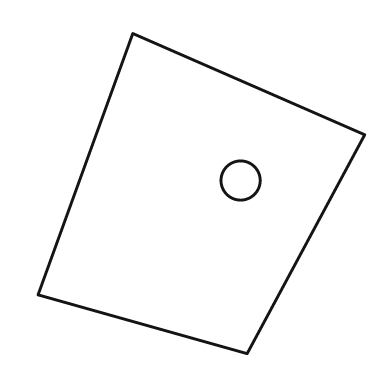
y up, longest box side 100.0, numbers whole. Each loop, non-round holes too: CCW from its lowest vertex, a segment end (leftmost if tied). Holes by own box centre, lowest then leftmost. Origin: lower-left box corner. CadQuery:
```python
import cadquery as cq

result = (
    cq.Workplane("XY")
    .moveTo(64.0, 0.0)
    .lineTo(100.0, 67.0)
    .lineTo(29.0, 98.0)
    .lineTo(0.0, 18.0)
    .close()
    .moveTo(62.0, 53.0)
    .circle(6.0)
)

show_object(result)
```